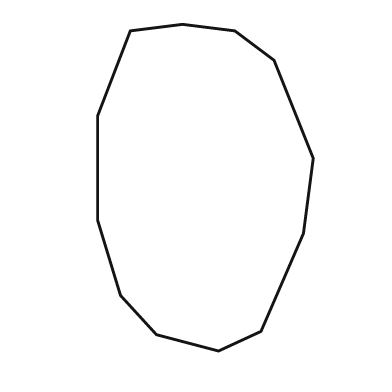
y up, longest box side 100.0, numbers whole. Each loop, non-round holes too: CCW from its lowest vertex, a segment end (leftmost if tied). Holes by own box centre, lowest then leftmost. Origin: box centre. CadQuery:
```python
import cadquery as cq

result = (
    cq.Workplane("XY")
    .moveTo(4.0, -50.0)
    .lineTo(17.0, -44.0)
    .lineTo(30.0, -14.0)
    .lineTo(33.0, 9.0)
    .lineTo(21.0, 39.0)
    .lineTo(9.0, 48.0)
    .lineTo(-7.0, 50.0)
    .lineTo(-23.0, 48.0)
    .lineTo(-33.0, 22.0)
    .lineTo(-33.0, -10.0)
    .lineTo(-26.0, -33.0)
    .lineTo(-15.0, -45.0)
    .close()
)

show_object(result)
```